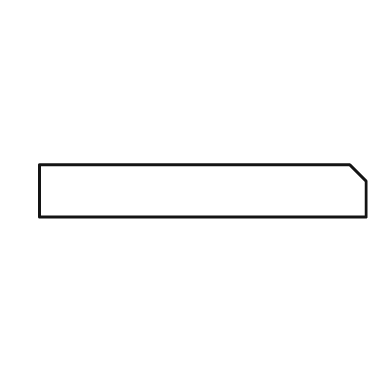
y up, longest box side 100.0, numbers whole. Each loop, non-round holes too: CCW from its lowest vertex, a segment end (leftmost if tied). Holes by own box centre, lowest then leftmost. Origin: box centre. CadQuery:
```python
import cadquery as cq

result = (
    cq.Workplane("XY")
    .moveTo(-50.0, -8.0)
    .lineTo(50.0, -8.0)
    .lineTo(50.0, 3.0)
    .lineTo(45.0, 8.0)
    .lineTo(-50.0, 8.0)
    .close()
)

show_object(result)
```